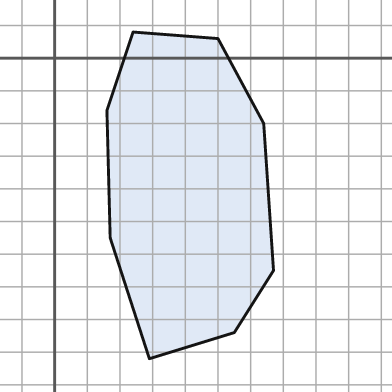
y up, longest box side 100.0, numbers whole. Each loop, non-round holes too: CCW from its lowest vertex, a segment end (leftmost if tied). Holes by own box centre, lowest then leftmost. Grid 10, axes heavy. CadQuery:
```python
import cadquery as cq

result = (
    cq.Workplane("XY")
    .moveTo(29.0, -92.0)
    .lineTo(55.0, -84.0)
    .lineTo(67.0, -65.0)
    .lineTo(64.0, -20.0)
    .lineTo(50.0, 6.0)
    .lineTo(24.0, 8.0)
    .lineTo(16.0, -16.0)
    .lineTo(17.0, -55.0)
    .close()
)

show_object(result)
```